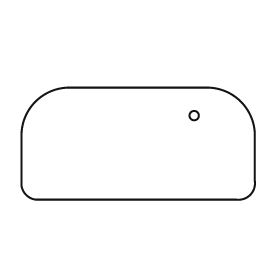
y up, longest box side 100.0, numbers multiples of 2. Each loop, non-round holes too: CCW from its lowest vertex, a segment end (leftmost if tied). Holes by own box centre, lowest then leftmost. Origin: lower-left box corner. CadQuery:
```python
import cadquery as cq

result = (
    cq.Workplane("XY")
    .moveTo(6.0, 0.0)
    .lineTo(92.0, 0.0)
    .threePointArc((98.0, 2.0), (100.0, 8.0))
    .lineTo(100.0, 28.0)
    .threePointArc((94.0, 42.0), (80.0, 48.0))
    .lineTo(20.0, 48.0)
    .threePointArc((6.0, 42.0), (0.0, 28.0))
    .lineTo(0.0, 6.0)
    .threePointArc((2.0, 2.0), (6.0, 0.0))
    .close()
    .moveTo(74.0, 36.0)
    .circle(2.0)
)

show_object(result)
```